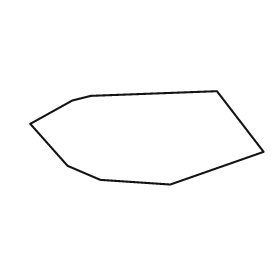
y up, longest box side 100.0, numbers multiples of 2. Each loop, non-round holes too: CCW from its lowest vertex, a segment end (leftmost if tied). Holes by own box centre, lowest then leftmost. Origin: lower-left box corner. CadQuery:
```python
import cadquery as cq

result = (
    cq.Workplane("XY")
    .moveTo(60.0, 0.0)
    .lineTo(100.0, 14.0)
    .lineTo(80.0, 40.0)
    .lineTo(26.0, 38.0)
    .lineTo(18.0, 36.0)
    .lineTo(0.0, 26.0)
    .lineTo(16.0, 8.0)
    .lineTo(30.0, 2.0)
    .close()
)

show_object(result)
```